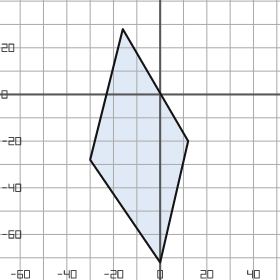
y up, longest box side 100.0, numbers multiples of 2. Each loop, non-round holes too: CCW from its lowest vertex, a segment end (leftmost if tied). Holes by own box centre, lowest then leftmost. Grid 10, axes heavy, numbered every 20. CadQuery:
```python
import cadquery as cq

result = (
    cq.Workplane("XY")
    .moveTo(0.0, -72.0)
    .lineTo(12.0, -20.0)
    .lineTo(-16.0, 28.0)
    .lineTo(-30.0, -28.0)
    .close()
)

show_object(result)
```